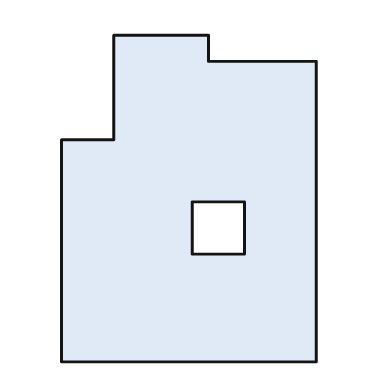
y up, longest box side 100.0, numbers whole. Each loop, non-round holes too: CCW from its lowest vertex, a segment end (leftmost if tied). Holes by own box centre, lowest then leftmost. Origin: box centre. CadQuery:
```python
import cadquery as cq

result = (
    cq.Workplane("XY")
    .moveTo(-39.0, -50.0)
    .lineTo(39.0, -50.0)
    .lineTo(39.0, 42.0)
    .lineTo(6.0, 42.0)
    .lineTo(6.0, 50.0)
    .lineTo(-23.0, 50.0)
    .lineTo(-23.0, 18.0)
    .lineTo(-39.0, 18.0)
    .close()
    .moveTo(1.0, -17.0)
    .lineTo(17.0, -17.0)
    .lineTo(17.0, -1.0)
    .lineTo(1.0, -1.0)
    .close()
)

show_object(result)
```